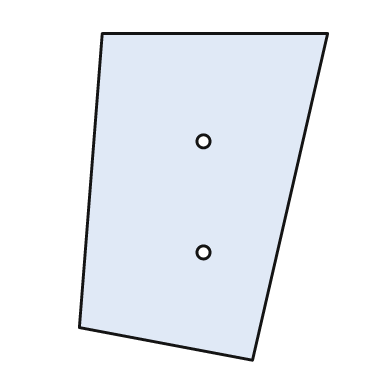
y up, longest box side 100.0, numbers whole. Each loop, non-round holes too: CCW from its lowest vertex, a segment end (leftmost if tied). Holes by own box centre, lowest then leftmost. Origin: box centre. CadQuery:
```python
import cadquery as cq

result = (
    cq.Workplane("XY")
    .moveTo(15.0, -50.0)
    .lineTo(38.0, 50.0)
    .lineTo(-31.0, 50.0)
    .lineTo(-38.0, -40.0)
    .close()
    .moveTo(0.0, -17.0)
    .circle(2.0)
    .moveTo(0.0, 17.0)
    .circle(2.0)
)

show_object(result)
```